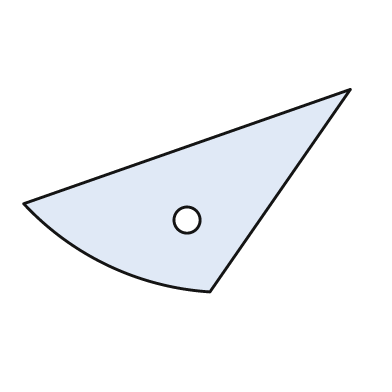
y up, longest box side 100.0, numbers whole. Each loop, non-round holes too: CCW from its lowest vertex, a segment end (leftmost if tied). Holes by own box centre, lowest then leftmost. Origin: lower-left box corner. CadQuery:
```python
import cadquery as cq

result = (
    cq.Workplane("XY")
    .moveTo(57.0, 0.0)
    .lineTo(100.0, 62.0)
    .lineTo(0.0, 27.0)
    .threePointArc((26.0, 8.0), (57.0, 0.0))
    .close()
    .moveTo(50.0, 22.0)
    .circle(4.0)
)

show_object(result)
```